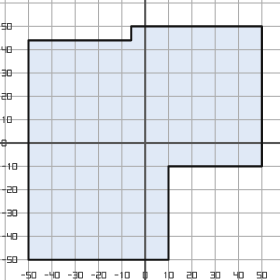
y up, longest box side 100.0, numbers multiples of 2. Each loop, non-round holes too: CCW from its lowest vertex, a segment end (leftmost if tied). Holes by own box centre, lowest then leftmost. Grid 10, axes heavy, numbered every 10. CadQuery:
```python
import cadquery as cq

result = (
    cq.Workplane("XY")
    .moveTo(-50.0, -50.0)
    .lineTo(10.0, -50.0)
    .lineTo(10.0, -10.0)
    .lineTo(50.0, -10.0)
    .lineTo(50.0, 50.0)
    .lineTo(-6.0, 50.0)
    .lineTo(-6.0, 44.0)
    .lineTo(-50.0, 44.0)
    .close()
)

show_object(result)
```